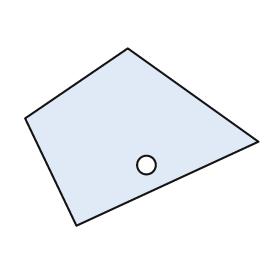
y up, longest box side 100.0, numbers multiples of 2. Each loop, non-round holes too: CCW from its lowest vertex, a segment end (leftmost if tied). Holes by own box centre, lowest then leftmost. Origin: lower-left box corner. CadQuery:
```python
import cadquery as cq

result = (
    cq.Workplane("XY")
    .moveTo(22.0, 0.0)
    .lineTo(100.0, 36.0)
    .lineTo(44.0, 76.0)
    .lineTo(0.0, 46.0)
    .close()
    .moveTo(52.0, 26.0)
    .circle(4.0)
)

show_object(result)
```